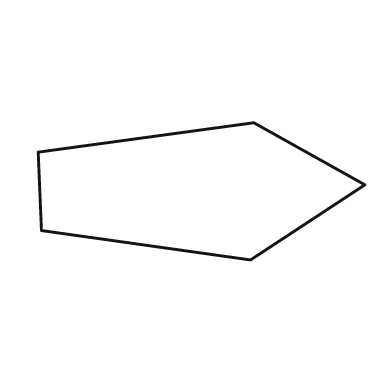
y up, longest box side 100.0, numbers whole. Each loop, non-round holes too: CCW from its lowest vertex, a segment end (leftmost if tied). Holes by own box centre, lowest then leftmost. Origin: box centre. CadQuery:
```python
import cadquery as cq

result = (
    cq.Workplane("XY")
    .moveTo(15.0, -21.0)
    .lineTo(50.0, 2.0)
    .lineTo(16.0, 21.0)
    .lineTo(-50.0, 12.0)
    .lineTo(-49.0, -12.0)
    .close()
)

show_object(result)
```